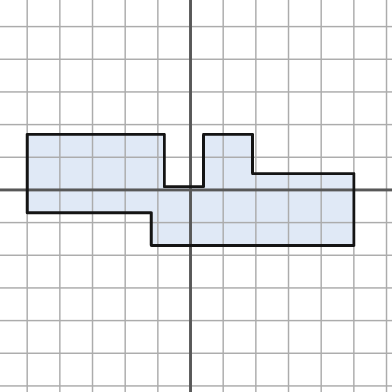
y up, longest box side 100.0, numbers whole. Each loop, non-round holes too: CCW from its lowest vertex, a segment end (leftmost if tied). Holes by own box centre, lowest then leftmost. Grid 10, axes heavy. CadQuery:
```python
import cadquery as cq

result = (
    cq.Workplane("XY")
    .moveTo(-12.0, -17.0)
    .lineTo(50.0, -17.0)
    .lineTo(50.0, 5.0)
    .lineTo(19.0, 5.0)
    .lineTo(19.0, 17.0)
    .lineTo(4.0, 17.0)
    .lineTo(4.0, 1.0)
    .lineTo(-8.0, 1.0)
    .lineTo(-8.0, 17.0)
    .lineTo(-50.0, 17.0)
    .lineTo(-50.0, -7.0)
    .lineTo(-12.0, -7.0)
    .close()
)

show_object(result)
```